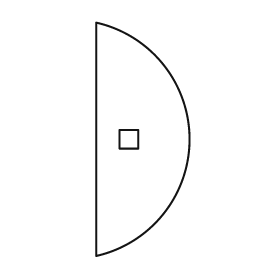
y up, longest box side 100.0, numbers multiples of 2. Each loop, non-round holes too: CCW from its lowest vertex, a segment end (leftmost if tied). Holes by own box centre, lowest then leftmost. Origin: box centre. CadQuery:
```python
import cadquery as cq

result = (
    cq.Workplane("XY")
    .moveTo(-20.0, -50.0)
    .threePointArc((20.0, 0.0), (-20.0, 50.0))
    .close()
    .moveTo(-10.0, -4.0)
    .lineTo(-2.0, -4.0)
    .lineTo(-2.0, 4.0)
    .lineTo(-10.0, 4.0)
    .close()
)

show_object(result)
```